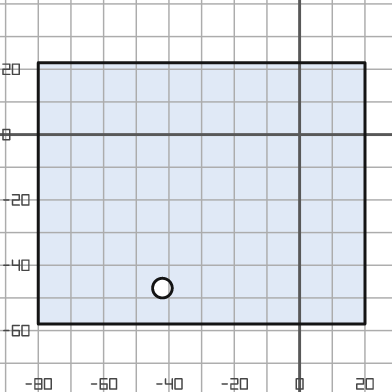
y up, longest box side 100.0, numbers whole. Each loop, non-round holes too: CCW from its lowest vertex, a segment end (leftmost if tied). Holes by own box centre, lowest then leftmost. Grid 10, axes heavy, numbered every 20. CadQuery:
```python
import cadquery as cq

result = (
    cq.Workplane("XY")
    .moveTo(-80.0, -58.0)
    .lineTo(20.0, -58.0)
    .lineTo(20.0, 22.0)
    .lineTo(-80.0, 22.0)
    .close()
    .moveTo(-42.0, -47.0)
    .circle(3.0)
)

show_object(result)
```